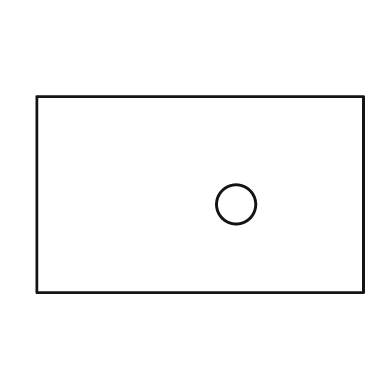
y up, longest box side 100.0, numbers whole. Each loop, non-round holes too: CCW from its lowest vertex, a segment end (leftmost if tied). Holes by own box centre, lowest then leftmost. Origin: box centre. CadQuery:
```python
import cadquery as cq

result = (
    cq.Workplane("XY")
    .moveTo(-50.0, -30.0)
    .lineTo(50.0, -30.0)
    .lineTo(50.0, 30.0)
    .lineTo(-50.0, 30.0)
    .close()
    .moveTo(11.0, -3.0)
    .circle(6.0)
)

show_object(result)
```